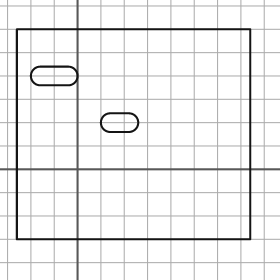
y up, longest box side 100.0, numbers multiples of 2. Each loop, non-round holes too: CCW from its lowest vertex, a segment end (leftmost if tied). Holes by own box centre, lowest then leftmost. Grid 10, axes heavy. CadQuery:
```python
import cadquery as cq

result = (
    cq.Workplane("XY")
    .moveTo(-26.0, -30.0)
    .lineTo(74.0, -30.0)
    .lineTo(74.0, 60.0)
    .lineTo(-26.0, 60.0)
    .close()
    .moveTo(14.0, 16.0)
    .lineTo(22.0, 16.0)
    .threePointArc((26.0, 20.0), (22.0, 24.0))
    .lineTo(14.0, 24.0)
    .threePointArc((10.0, 20.0), (14.0, 16.0))
    .close()
    .moveTo(-16.0, 36.0)
    .lineTo(-4.0, 36.0)
    .threePointArc((0.0, 40.0), (-4.0, 44.0))
    .lineTo(-16.0, 44.0)
    .threePointArc((-20.0, 40.0), (-16.0, 36.0))
    .close()
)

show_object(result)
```